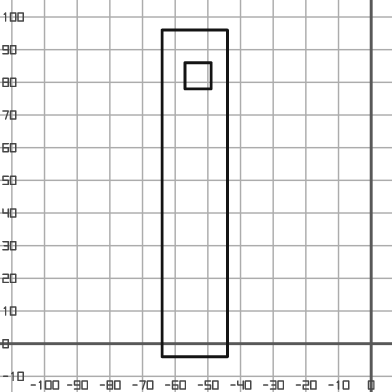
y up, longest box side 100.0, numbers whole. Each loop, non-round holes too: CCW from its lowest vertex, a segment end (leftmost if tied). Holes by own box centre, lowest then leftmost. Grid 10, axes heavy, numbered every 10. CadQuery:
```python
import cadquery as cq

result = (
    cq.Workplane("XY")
    .moveTo(-64.0, -4.0)
    .lineTo(-44.0, -4.0)
    .lineTo(-44.0, 96.0)
    .lineTo(-64.0, 96.0)
    .close()
    .moveTo(-57.0, 78.0)
    .lineTo(-49.0, 78.0)
    .lineTo(-49.0, 86.0)
    .lineTo(-57.0, 86.0)
    .close()
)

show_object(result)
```